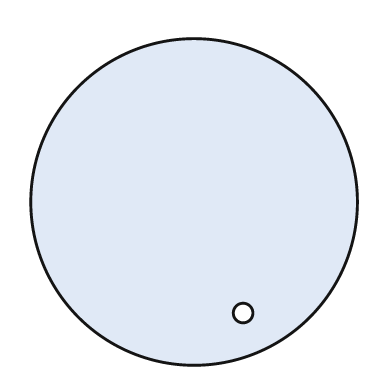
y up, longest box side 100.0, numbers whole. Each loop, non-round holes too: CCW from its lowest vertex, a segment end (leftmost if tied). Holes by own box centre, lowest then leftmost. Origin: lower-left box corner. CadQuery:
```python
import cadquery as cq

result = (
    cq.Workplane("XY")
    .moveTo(50.0, 50.0)
    .circle(50.0)
    .moveTo(65.0, 16.0)
    .circle(3.0)
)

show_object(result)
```